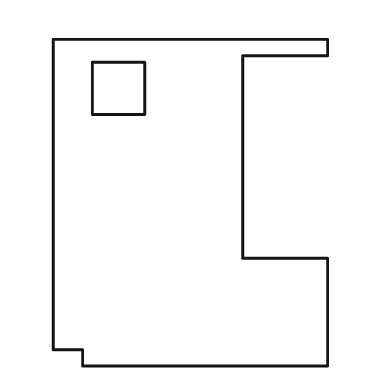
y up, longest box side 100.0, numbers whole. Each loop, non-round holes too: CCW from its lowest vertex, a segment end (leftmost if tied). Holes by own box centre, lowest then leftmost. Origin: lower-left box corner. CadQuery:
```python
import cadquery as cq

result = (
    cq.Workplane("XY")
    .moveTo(9.0, 0.0)
    .lineTo(84.0, 0.0)
    .lineTo(84.0, 33.0)
    .lineTo(58.0, 33.0)
    .lineTo(58.0, 95.0)
    .lineTo(84.0, 95.0)
    .lineTo(84.0, 100.0)
    .lineTo(0.0, 100.0)
    .lineTo(0.0, 5.0)
    .lineTo(9.0, 5.0)
    .close()
    .moveTo(12.0, 77.0)
    .lineTo(28.0, 77.0)
    .lineTo(28.0, 93.0)
    .lineTo(12.0, 93.0)
    .close()
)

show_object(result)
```